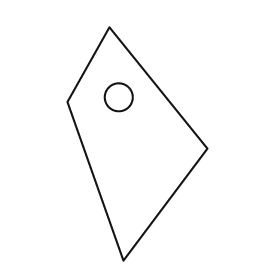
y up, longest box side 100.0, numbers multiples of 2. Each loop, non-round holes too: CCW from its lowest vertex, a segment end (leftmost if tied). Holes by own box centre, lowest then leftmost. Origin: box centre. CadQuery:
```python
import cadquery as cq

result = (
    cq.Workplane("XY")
    .moveTo(-6.0, -50.0)
    .lineTo(30.0, -2.0)
    .lineTo(-12.0, 50.0)
    .lineTo(-30.0, 18.0)
    .close()
    .moveTo(-8.0, 20.0)
    .circle(6.0)
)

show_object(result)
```